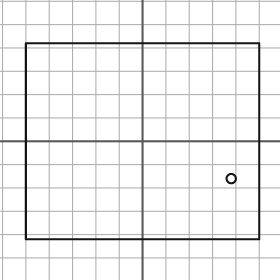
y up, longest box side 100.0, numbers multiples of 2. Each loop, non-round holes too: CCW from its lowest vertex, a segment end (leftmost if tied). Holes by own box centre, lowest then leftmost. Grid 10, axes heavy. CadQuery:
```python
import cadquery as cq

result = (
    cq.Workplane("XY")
    .moveTo(-50.0, -42.0)
    .lineTo(50.0, -42.0)
    .lineTo(50.0, 42.0)
    .lineTo(-50.0, 42.0)
    .close()
    .moveTo(38.0, -16.0)
    .circle(2.0)
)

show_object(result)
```